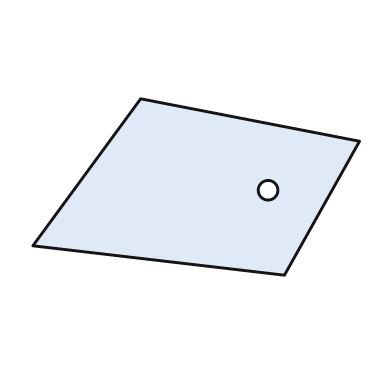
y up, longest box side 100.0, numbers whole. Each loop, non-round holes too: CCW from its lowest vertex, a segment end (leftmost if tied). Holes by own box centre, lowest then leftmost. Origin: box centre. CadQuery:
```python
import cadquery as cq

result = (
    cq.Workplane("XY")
    .moveTo(27.0, -27.0)
    .lineTo(50.0, 14.0)
    .lineTo(-17.0, 27.0)
    .lineTo(-50.0, -18.0)
    .close()
    .moveTo(22.0, -1.0)
    .circle(3.0)
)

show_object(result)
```